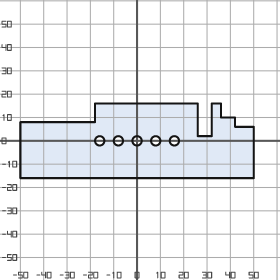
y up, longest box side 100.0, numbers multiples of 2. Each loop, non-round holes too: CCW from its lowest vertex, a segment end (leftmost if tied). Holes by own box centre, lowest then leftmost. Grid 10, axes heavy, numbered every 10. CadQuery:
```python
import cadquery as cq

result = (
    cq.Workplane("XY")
    .moveTo(-50.0, -16.0)
    .lineTo(50.0, -16.0)
    .lineTo(50.0, 6.0)
    .lineTo(42.0, 6.0)
    .lineTo(42.0, 10.0)
    .lineTo(36.0, 10.0)
    .lineTo(36.0, 16.0)
    .lineTo(32.0, 16.0)
    .lineTo(32.0, 2.0)
    .lineTo(26.0, 2.0)
    .lineTo(26.0, 16.0)
    .lineTo(-18.0, 16.0)
    .lineTo(-18.0, 8.0)
    .lineTo(-50.0, 8.0)
    .close()
    .moveTo(-16.0, 0.0)
    .circle(2.0)
    .moveTo(-8.0, 0.0)
    .circle(2.0)
    .moveTo(0.0, 0.0)
    .circle(2.0)
    .moveTo(8.0, 0.0)
    .circle(2.0)
    .moveTo(16.0, 0.0)
    .circle(2.0)
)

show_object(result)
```